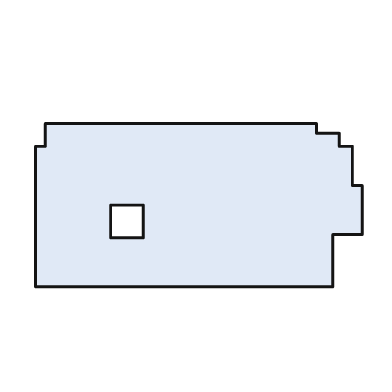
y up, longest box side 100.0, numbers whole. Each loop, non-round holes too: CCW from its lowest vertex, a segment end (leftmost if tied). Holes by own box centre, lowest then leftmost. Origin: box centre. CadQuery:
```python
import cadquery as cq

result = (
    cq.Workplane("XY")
    .moveTo(-50.0, -25.0)
    .lineTo(41.0, -25.0)
    .lineTo(41.0, -9.0)
    .lineTo(50.0, -9.0)
    .lineTo(50.0, 6.0)
    .lineTo(47.0, 6.0)
    .lineTo(47.0, 18.0)
    .lineTo(43.0, 18.0)
    .lineTo(43.0, 22.0)
    .lineTo(36.0, 22.0)
    .lineTo(36.0, 25.0)
    .lineTo(-47.0, 25.0)
    .lineTo(-47.0, 18.0)
    .lineTo(-50.0, 18.0)
    .close()
    .moveTo(-27.0, -10.0)
    .lineTo(-17.0, -10.0)
    .lineTo(-17.0, 0.0)
    .lineTo(-27.0, 0.0)
    .close()
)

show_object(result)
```